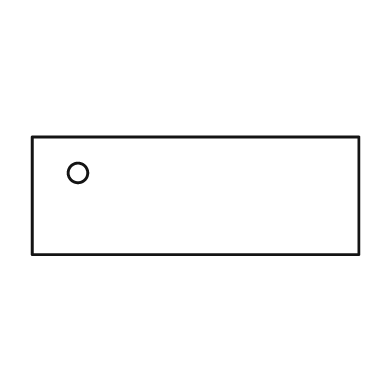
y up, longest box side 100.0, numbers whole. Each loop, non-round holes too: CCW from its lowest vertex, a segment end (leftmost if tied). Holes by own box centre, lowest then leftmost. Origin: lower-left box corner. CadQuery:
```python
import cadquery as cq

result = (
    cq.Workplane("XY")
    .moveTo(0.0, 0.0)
    .lineTo(100.0, 0.0)
    .lineTo(100.0, 36.0)
    .lineTo(0.0, 36.0)
    .close()
    .moveTo(14.0, 25.0)
    .circle(3.0)
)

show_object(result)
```